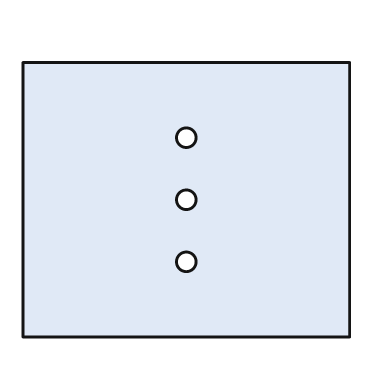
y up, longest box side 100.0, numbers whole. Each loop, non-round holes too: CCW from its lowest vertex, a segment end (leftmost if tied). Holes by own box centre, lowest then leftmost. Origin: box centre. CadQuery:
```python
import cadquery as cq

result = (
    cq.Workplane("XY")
    .moveTo(-50.0, -42.0)
    .lineTo(50.0, -42.0)
    .lineTo(50.0, 42.0)
    .lineTo(-50.0, 42.0)
    .close()
    .moveTo(0.0, -19.0)
    .circle(3.0)
    .moveTo(0.0, 0.0)
    .circle(3.0)
    .moveTo(0.0, 19.0)
    .circle(3.0)
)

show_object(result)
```